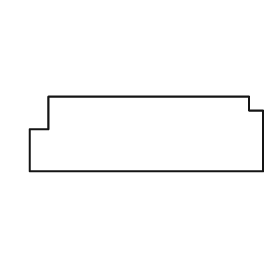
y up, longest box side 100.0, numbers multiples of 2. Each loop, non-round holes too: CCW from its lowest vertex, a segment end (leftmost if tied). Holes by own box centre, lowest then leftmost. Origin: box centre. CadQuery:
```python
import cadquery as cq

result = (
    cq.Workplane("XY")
    .moveTo(-50.0, -16.0)
    .lineTo(50.0, -16.0)
    .lineTo(50.0, 10.0)
    .lineTo(44.0, 10.0)
    .lineTo(44.0, 16.0)
    .lineTo(-42.0, 16.0)
    .lineTo(-42.0, 2.0)
    .lineTo(-50.0, 2.0)
    .close()
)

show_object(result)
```